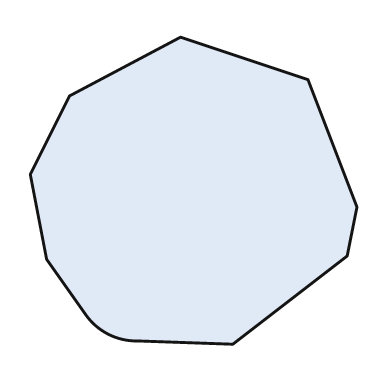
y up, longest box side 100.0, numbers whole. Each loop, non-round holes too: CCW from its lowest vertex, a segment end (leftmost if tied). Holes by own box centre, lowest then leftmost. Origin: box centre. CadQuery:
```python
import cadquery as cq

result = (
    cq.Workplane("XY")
    .moveTo(12.0, -47.0)
    .lineTo(47.0, -20.0)
    .lineTo(50.0, -5.0)
    .lineTo(35.0, 34.0)
    .lineTo(-4.0, 47.0)
    .lineTo(-38.0, 29.0)
    .lineTo(-50.0, 5.0)
    .lineTo(-45.0, -21.0)
    .lineTo(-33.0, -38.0)
    .threePointArc((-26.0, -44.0), (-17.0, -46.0))
    .close()
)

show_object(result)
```